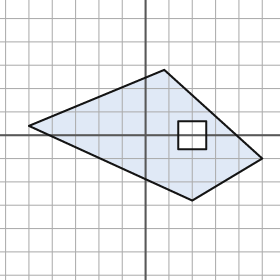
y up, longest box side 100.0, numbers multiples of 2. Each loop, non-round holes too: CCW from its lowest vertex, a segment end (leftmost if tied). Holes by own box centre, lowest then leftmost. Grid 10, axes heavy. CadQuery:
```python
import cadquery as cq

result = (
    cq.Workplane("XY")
    .moveTo(20.0, -28.0)
    .lineTo(50.0, -10.0)
    .lineTo(8.0, 28.0)
    .lineTo(-50.0, 4.0)
    .close()
    .moveTo(14.0, -6.0)
    .lineTo(26.0, -6.0)
    .lineTo(26.0, 6.0)
    .lineTo(14.0, 6.0)
    .close()
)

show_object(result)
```